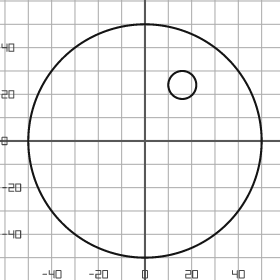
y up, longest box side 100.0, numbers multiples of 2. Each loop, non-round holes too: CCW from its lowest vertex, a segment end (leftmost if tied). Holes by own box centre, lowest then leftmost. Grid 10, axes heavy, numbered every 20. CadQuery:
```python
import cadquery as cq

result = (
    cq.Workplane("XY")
    .moveTo(0.0, 0.0)
    .circle(50.0)
    .moveTo(16.0, 24.0)
    .circle(6.0)
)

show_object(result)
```